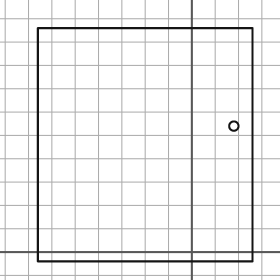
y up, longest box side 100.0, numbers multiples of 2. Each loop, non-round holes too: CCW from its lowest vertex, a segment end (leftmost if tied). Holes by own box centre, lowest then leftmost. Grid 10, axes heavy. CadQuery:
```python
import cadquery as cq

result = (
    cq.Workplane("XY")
    .moveTo(-66.0, -4.0)
    .lineTo(26.0, -4.0)
    .lineTo(26.0, 96.0)
    .lineTo(-66.0, 96.0)
    .close()
    .moveTo(18.0, 54.0)
    .circle(2.0)
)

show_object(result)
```